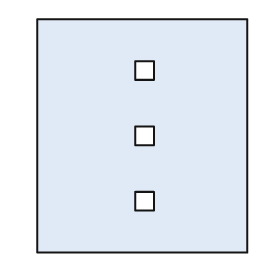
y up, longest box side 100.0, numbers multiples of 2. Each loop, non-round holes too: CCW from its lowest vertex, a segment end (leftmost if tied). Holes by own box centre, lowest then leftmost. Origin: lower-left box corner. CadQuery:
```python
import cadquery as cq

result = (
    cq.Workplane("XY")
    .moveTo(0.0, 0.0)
    .lineTo(90.0, 0.0)
    .lineTo(90.0, 100.0)
    .lineTo(0.0, 100.0)
    .close()
    .moveTo(42.0, 18.0)
    .lineTo(50.0, 18.0)
    .lineTo(50.0, 26.0)
    .lineTo(42.0, 26.0)
    .close()
    .moveTo(42.0, 46.0)
    .lineTo(50.0, 46.0)
    .lineTo(50.0, 54.0)
    .lineTo(42.0, 54.0)
    .close()
    .moveTo(42.0, 74.0)
    .lineTo(50.0, 74.0)
    .lineTo(50.0, 82.0)
    .lineTo(42.0, 82.0)
    .close()
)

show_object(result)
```